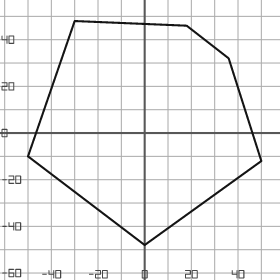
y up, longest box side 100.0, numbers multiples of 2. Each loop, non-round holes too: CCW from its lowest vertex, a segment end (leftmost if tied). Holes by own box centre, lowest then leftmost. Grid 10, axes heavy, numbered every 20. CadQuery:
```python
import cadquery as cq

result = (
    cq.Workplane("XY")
    .moveTo(0.0, -48.0)
    .lineTo(50.0, -12.0)
    .lineTo(36.0, 32.0)
    .lineTo(18.0, 46.0)
    .lineTo(-30.0, 48.0)
    .lineTo(-50.0, -10.0)
    .close()
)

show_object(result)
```